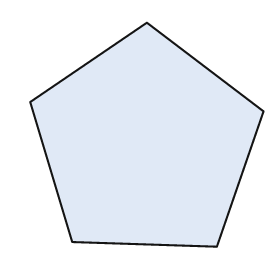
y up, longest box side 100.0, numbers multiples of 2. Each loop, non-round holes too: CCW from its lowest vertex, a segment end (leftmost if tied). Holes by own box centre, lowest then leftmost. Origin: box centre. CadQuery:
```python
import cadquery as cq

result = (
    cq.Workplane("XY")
    .moveTo(30.0, -48.0)
    .lineTo(50.0, 10.0)
    .lineTo(0.0, 48.0)
    .lineTo(-50.0, 14.0)
    .lineTo(-32.0, -46.0)
    .close()
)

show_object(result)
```